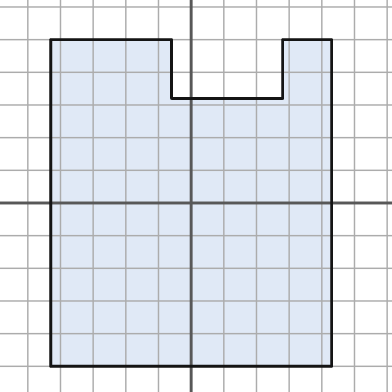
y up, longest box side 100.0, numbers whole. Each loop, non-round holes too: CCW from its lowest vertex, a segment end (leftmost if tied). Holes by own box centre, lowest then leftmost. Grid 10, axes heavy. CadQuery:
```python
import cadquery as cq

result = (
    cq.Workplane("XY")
    .moveTo(-43.0, -50.0)
    .lineTo(43.0, -50.0)
    .lineTo(43.0, 50.0)
    .lineTo(28.0, 50.0)
    .lineTo(28.0, 32.0)
    .lineTo(-6.0, 32.0)
    .lineTo(-6.0, 50.0)
    .lineTo(-43.0, 50.0)
    .close()
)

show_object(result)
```